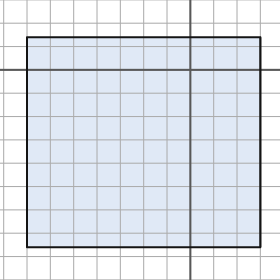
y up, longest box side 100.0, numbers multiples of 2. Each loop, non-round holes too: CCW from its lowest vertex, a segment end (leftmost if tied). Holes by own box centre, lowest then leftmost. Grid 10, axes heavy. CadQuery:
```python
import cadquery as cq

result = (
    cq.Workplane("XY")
    .moveTo(-70.0, -76.0)
    .lineTo(30.0, -76.0)
    .lineTo(30.0, 14.0)
    .lineTo(-70.0, 14.0)
    .close()
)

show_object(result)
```